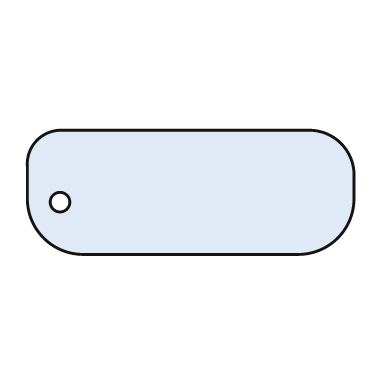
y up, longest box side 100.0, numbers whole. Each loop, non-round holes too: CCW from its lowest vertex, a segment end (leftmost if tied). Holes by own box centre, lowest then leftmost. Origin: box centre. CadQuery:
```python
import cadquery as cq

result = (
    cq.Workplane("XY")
    .moveTo(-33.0, -19.0)
    .lineTo(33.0, -19.0)
    .threePointArc((45.0, -14.0), (50.0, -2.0))
    .lineTo(50.0, 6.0)
    .threePointArc((46.0, 15.0), (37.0, 19.0))
    .lineTo(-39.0, 19.0)
    .threePointArc((-47.0, 16.0), (-50.0, 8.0))
    .lineTo(-50.0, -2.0)
    .threePointArc((-45.0, -14.0), (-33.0, -19.0))
    .close()
    .moveTo(-40.0, -3.0)
    .circle(3.0)
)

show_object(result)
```